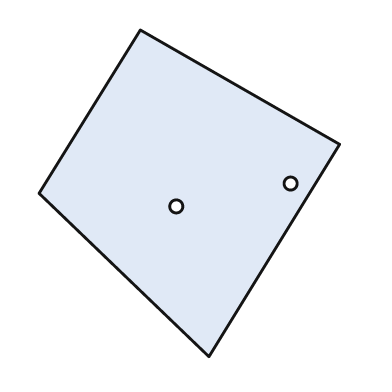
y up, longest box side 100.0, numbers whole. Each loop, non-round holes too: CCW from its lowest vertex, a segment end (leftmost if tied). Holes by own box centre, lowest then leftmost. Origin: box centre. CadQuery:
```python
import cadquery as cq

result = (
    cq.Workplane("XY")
    .moveTo(6.0, -50.0)
    .lineTo(46.0, 15.0)
    .lineTo(-15.0, 50.0)
    .lineTo(-46.0, 0.0)
    .close()
    .moveTo(-4.0, -4.0)
    .circle(2.0)
    .moveTo(31.0, 3.0)
    .circle(2.0)
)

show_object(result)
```